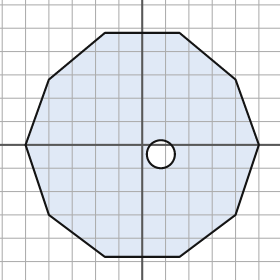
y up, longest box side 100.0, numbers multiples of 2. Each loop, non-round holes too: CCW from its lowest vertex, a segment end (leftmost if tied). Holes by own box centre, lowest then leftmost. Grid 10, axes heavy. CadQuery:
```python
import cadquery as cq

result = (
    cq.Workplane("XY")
    .moveTo(-16.0, -48.0)
    .lineTo(16.0, -48.0)
    .lineTo(40.0, -30.0)
    .lineTo(50.0, 0.0)
    .lineTo(40.0, 28.0)
    .lineTo(16.0, 48.0)
    .lineTo(-16.0, 48.0)
    .lineTo(-40.0, 28.0)
    .lineTo(-50.0, 0.0)
    .lineTo(-40.0, -30.0)
    .close()
    .moveTo(8.0, -4.0)
    .circle(6.0)
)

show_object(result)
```